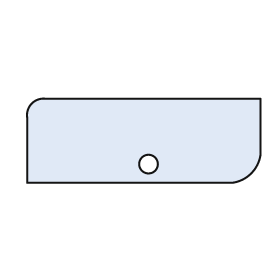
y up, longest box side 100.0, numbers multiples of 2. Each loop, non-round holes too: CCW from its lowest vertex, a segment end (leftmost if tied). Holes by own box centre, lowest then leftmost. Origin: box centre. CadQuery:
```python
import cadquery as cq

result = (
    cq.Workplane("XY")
    .moveTo(-50.0, -18.0)
    .lineTo(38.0, -18.0)
    .threePointArc((46.0, -14.0), (50.0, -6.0))
    .lineTo(50.0, 18.0)
    .lineTo(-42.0, 18.0)
    .threePointArc((-48.0, 16.0), (-50.0, 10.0))
    .close()
    .moveTo(2.0, -10.0)
    .circle(4.0)
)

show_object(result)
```